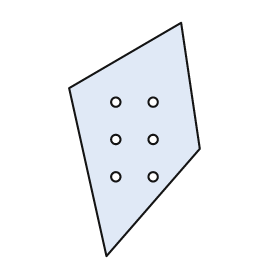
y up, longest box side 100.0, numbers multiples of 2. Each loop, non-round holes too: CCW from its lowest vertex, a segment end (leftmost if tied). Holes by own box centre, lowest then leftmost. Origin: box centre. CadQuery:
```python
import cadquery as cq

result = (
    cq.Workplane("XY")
    .moveTo(-12.0, -50.0)
    .lineTo(28.0, -4.0)
    .lineTo(20.0, 50.0)
    .lineTo(-28.0, 22.0)
    .close()
    .moveTo(-8.0, -16.0)
    .circle(2.0)
    .moveTo(8.0, -16.0)
    .circle(2.0)
    .moveTo(-8.0, 0.0)
    .circle(2.0)
    .moveTo(8.0, 0.0)
    .circle(2.0)
    .moveTo(-8.0, 16.0)
    .circle(2.0)
    .moveTo(8.0, 16.0)
    .circle(2.0)
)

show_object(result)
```